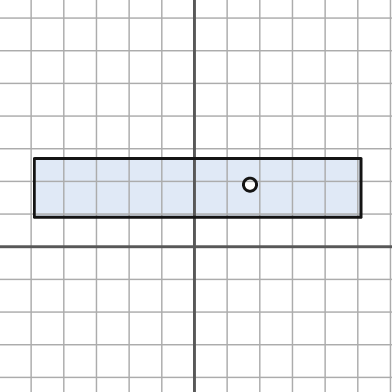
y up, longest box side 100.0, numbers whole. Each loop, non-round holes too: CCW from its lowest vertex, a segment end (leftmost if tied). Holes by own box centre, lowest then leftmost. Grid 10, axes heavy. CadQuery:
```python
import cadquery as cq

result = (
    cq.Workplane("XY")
    .moveTo(-49.0, 9.0)
    .lineTo(51.0, 9.0)
    .lineTo(51.0, 27.0)
    .lineTo(-49.0, 27.0)
    .close()
    .moveTo(17.0, 19.0)
    .circle(2.0)
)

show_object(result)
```